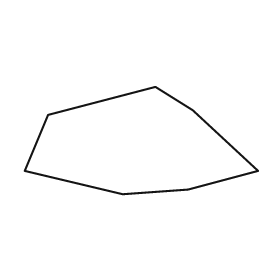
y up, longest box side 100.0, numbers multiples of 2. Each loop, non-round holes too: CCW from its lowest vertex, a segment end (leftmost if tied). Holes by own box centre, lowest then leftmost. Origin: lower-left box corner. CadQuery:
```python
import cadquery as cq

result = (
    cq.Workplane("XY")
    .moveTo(42.0, 0.0)
    .lineTo(70.0, 2.0)
    .lineTo(100.0, 10.0)
    .lineTo(72.0, 36.0)
    .lineTo(56.0, 46.0)
    .lineTo(10.0, 34.0)
    .lineTo(0.0, 10.0)
    .close()
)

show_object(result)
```